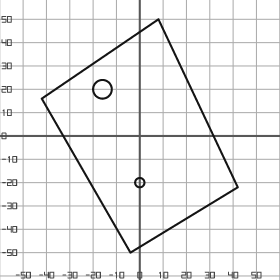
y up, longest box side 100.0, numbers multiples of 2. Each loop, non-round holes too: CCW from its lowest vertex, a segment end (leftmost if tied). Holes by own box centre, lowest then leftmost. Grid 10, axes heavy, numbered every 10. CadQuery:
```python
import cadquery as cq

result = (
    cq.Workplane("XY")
    .moveTo(-4.0, -50.0)
    .lineTo(42.0, -22.0)
    .lineTo(8.0, 50.0)
    .lineTo(-42.0, 16.0)
    .close()
    .moveTo(0.0, -20.0)
    .circle(2.0)
    .moveTo(-16.0, 20.0)
    .circle(4.0)
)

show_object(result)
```